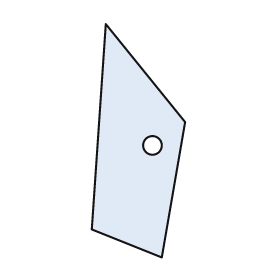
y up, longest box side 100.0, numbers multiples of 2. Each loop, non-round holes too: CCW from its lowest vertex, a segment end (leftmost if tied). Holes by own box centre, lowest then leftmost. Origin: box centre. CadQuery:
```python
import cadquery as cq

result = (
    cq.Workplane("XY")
    .moveTo(10.0, -50.0)
    .lineTo(20.0, 8.0)
    .lineTo(-14.0, 50.0)
    .lineTo(-20.0, -38.0)
    .close()
    .moveTo(6.0, -2.0)
    .circle(4.0)
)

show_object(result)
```